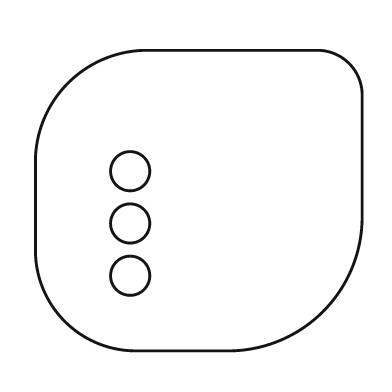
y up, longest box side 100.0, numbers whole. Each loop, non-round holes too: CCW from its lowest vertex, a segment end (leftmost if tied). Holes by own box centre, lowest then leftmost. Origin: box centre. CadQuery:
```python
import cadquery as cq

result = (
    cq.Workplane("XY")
    .moveTo(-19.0, -46.0)
    .lineTo(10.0, -46.0)
    .threePointArc((38.0, -34.0), (50.0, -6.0))
    .lineTo(50.0, 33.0)
    .threePointArc((46.0, 42.0), (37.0, 46.0))
    .lineTo(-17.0, 46.0)
    .threePointArc((-40.0, 36.0), (-50.0, 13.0))
    .lineTo(-50.0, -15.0)
    .threePointArc((-41.0, -37.0), (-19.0, -46.0))
    .close()
    .moveTo(-21.0, -23.0)
    .circle(6.0)
    .moveTo(-21.0, -7.0)
    .circle(6.0)
    .moveTo(-21.0, 9.0)
    .circle(6.0)
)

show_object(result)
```